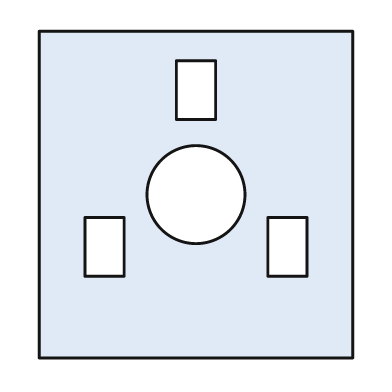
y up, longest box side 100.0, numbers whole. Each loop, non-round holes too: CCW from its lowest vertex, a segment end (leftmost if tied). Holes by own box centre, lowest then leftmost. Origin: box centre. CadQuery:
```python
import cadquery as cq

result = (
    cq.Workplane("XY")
    .moveTo(-48.0, -50.0)
    .lineTo(48.0, -50.0)
    .lineTo(48.0, 50.0)
    .lineTo(-48.0, 50.0)
    .close()
    .moveTo(-34.0, -25.0)
    .lineTo(-22.0, -25.0)
    .lineTo(-22.0, -7.0)
    .lineTo(-34.0, -7.0)
    .close()
    .moveTo(22.0, -25.0)
    .lineTo(34.0, -25.0)
    .lineTo(34.0, -7.0)
    .lineTo(22.0, -7.0)
    .close()
    .moveTo(0.0, 0.0)
    .circle(15.0)
    .moveTo(-6.0, 23.0)
    .lineTo(6.0, 23.0)
    .lineTo(6.0, 41.0)
    .lineTo(-6.0, 41.0)
    .close()
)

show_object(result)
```